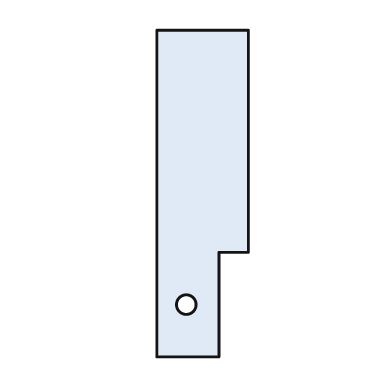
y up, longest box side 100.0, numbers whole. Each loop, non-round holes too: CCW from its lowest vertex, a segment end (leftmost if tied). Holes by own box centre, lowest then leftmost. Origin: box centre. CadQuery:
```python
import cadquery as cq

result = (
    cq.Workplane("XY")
    .moveTo(-14.0, -50.0)
    .lineTo(5.0, -50.0)
    .lineTo(5.0, -18.0)
    .lineTo(14.0, -18.0)
    .lineTo(14.0, 50.0)
    .lineTo(-14.0, 50.0)
    .close()
    .moveTo(-5.0, -34.0)
    .circle(3.0)
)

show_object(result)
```